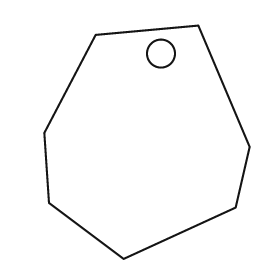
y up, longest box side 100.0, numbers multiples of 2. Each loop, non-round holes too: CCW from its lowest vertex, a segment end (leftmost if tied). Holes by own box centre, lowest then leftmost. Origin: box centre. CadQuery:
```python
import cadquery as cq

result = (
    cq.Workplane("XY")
    .moveTo(-10.0, -50.0)
    .lineTo(38.0, -28.0)
    .lineTo(44.0, -2.0)
    .lineTo(22.0, 50.0)
    .lineTo(-22.0, 46.0)
    .lineTo(-44.0, 4.0)
    .lineTo(-42.0, -26.0)
    .close()
    .moveTo(6.0, 38.0)
    .circle(6.0)
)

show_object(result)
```